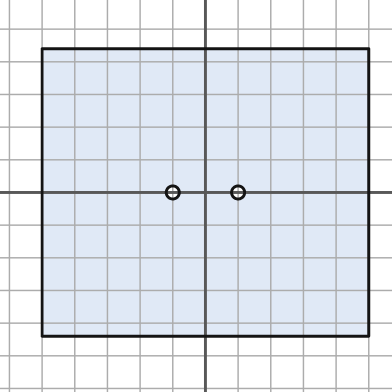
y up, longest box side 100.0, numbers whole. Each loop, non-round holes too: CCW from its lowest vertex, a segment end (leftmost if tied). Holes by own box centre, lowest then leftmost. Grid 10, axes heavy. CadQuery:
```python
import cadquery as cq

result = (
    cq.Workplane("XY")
    .moveTo(-50.0, -44.0)
    .lineTo(50.0, -44.0)
    .lineTo(50.0, 44.0)
    .lineTo(-50.0, 44.0)
    .close()
    .moveTo(-10.0, 0.0)
    .circle(2.0)
    .moveTo(10.0, 0.0)
    .circle(2.0)
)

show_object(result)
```